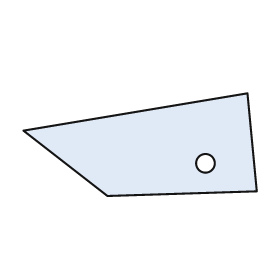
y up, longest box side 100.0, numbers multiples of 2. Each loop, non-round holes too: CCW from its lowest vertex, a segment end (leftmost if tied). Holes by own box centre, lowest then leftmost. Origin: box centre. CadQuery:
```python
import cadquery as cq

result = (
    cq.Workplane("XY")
    .moveTo(-14.0, -22.0)
    .lineTo(50.0, -20.0)
    .lineTo(46.0, 22.0)
    .lineTo(-50.0, 6.0)
    .close()
    .moveTo(28.0, -8.0)
    .circle(4.0)
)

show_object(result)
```